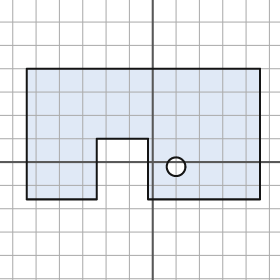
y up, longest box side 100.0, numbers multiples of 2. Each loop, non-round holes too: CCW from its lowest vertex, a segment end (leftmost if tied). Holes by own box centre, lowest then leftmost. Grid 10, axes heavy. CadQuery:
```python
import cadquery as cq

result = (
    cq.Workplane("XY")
    .moveTo(-54.0, -16.0)
    .lineTo(-24.0, -16.0)
    .lineTo(-24.0, 10.0)
    .lineTo(-2.0, 10.0)
    .lineTo(-2.0, -16.0)
    .lineTo(46.0, -16.0)
    .lineTo(46.0, 40.0)
    .lineTo(-54.0, 40.0)
    .close()
    .moveTo(10.0, -2.0)
    .circle(4.0)
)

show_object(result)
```